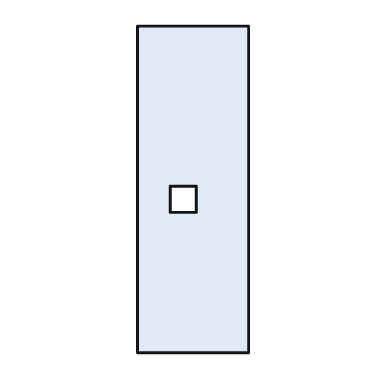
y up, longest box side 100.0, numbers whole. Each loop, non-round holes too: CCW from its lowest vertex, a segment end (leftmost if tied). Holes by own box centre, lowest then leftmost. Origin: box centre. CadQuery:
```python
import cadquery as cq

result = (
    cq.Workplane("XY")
    .moveTo(-17.0, -50.0)
    .lineTo(17.0, -50.0)
    .lineTo(17.0, 50.0)
    .lineTo(-17.0, 50.0)
    .close()
    .moveTo(-7.0, -7.0)
    .lineTo(1.0, -7.0)
    .lineTo(1.0, 1.0)
    .lineTo(-7.0, 1.0)
    .close()
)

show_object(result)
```